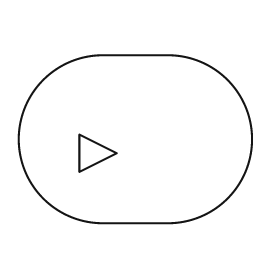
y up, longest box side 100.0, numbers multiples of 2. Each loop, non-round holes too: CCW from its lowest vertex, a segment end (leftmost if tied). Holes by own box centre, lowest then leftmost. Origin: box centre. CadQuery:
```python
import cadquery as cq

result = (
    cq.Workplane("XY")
    .moveTo(-14.0, -36.0)
    .lineTo(14.0, -36.0)
    .threePointArc((50.0, 0.0), (14.0, 36.0))
    .lineTo(-14.0, 36.0)
    .threePointArc((-50.0, 0.0), (-14.0, -36.0))
    .close()
    .moveTo(-24.0, -14.0)
    .lineTo(-8.0, -6.0)
    .lineTo(-24.0, 2.0)
    .close()
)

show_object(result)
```